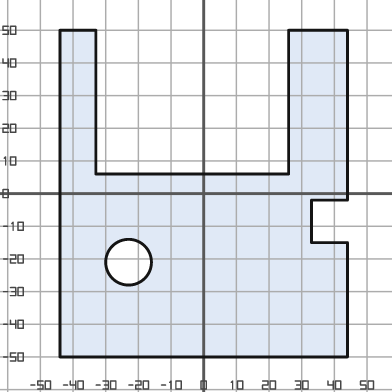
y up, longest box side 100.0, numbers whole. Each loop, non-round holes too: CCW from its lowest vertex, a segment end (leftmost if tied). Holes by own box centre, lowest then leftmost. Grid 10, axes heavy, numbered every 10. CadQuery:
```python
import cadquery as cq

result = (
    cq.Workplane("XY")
    .moveTo(-44.0, -50.0)
    .lineTo(44.0, -50.0)
    .lineTo(44.0, -15.0)
    .lineTo(33.0, -15.0)
    .lineTo(33.0, -2.0)
    .lineTo(44.0, -2.0)
    .lineTo(44.0, 50.0)
    .lineTo(26.0, 50.0)
    .lineTo(26.0, 6.0)
    .lineTo(-33.0, 6.0)
    .lineTo(-33.0, 50.0)
    .lineTo(-44.0, 50.0)
    .close()
    .moveTo(-23.0, -21.0)
    .circle(7.0)
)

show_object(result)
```